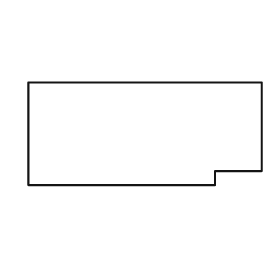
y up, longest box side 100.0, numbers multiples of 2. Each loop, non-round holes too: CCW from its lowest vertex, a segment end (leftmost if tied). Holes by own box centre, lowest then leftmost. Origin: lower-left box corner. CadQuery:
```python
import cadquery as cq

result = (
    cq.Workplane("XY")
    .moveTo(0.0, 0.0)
    .lineTo(80.0, 0.0)
    .lineTo(80.0, 6.0)
    .lineTo(100.0, 6.0)
    .lineTo(100.0, 44.0)
    .lineTo(0.0, 44.0)
    .close()
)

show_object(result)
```